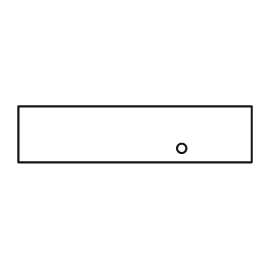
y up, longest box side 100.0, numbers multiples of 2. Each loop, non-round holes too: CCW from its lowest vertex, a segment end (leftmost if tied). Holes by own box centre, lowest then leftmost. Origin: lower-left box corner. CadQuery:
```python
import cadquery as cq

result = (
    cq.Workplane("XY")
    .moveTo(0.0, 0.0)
    .lineTo(100.0, 0.0)
    .lineTo(100.0, 24.0)
    .lineTo(0.0, 24.0)
    .close()
    .moveTo(70.0, 6.0)
    .circle(2.0)
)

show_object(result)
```